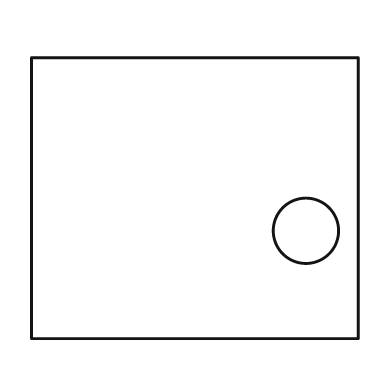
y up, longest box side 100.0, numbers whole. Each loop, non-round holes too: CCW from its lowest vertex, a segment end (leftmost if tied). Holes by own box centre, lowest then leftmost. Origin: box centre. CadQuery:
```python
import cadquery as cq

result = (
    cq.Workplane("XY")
    .moveTo(-50.0, -43.0)
    .lineTo(50.0, -43.0)
    .lineTo(50.0, 43.0)
    .lineTo(-50.0, 43.0)
    .close()
    .moveTo(34.0, -10.0)
    .circle(10.0)
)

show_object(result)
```